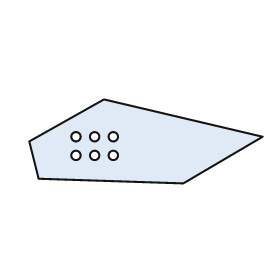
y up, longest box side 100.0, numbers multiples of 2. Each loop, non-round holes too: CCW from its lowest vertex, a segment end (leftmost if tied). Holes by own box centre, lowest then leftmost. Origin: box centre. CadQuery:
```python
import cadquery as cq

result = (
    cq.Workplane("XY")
    .moveTo(16.0, -18.0)
    .lineTo(50.0, 2.0)
    .lineTo(-18.0, 18.0)
    .lineTo(-50.0, 0.0)
    .lineTo(-46.0, -16.0)
    .close()
    .moveTo(-30.0, -6.0)
    .circle(2.0)
    .moveTo(-22.0, -6.0)
    .circle(2.0)
    .moveTo(-14.0, -6.0)
    .circle(2.0)
    .moveTo(-30.0, 2.0)
    .circle(2.0)
    .moveTo(-22.0, 2.0)
    .circle(2.0)
    .moveTo(-14.0, 2.0)
    .circle(2.0)
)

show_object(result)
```